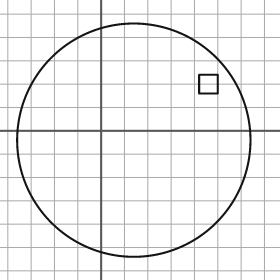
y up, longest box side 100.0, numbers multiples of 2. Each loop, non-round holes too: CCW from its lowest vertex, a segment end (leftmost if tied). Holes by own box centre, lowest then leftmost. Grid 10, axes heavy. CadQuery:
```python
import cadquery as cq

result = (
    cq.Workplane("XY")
    .moveTo(14.0, -4.0)
    .circle(50.0)
    .moveTo(42.0, 16.0)
    .lineTo(50.0, 16.0)
    .lineTo(50.0, 24.0)
    .lineTo(42.0, 24.0)
    .close()
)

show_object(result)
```